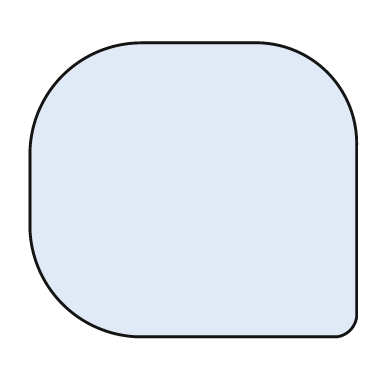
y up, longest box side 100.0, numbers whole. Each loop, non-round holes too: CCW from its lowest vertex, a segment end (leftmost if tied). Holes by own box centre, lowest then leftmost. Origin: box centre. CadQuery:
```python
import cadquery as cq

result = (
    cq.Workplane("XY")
    .moveTo(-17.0, -45.0)
    .lineTo(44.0, -45.0)
    .threePointArc((48.0, -43.0), (50.0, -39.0))
    .lineTo(50.0, 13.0)
    .threePointArc((41.0, 36.0), (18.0, 45.0))
    .lineTo(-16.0, 45.0)
    .threePointArc((-40.0, 35.0), (-50.0, 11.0))
    .lineTo(-50.0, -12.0)
    .threePointArc((-40.0, -35.0), (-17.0, -45.0))
    .close()
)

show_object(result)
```